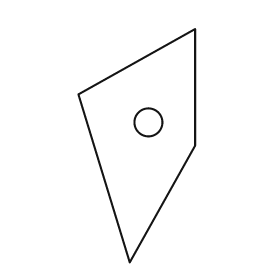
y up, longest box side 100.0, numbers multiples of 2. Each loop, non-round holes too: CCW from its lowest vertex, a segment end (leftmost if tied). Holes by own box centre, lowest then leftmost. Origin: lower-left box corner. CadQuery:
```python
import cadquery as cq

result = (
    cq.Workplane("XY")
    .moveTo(22.0, 0.0)
    .lineTo(50.0, 50.0)
    .lineTo(50.0, 100.0)
    .lineTo(0.0, 72.0)
    .close()
    .moveTo(30.0, 60.0)
    .circle(6.0)
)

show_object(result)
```